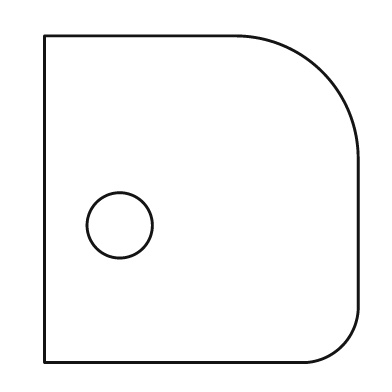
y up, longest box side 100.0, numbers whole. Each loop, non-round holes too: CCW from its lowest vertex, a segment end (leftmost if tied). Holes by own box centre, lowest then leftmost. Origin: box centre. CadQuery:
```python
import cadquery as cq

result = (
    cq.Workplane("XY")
    .moveTo(-48.0, -50.0)
    .lineTo(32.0, -50.0)
    .threePointArc((43.0, -45.0), (48.0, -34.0))
    .lineTo(48.0, 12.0)
    .threePointArc((37.0, 39.0), (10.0, 50.0))
    .lineTo(-48.0, 50.0)
    .close()
    .moveTo(-25.0, -8.0)
    .circle(10.0)
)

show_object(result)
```